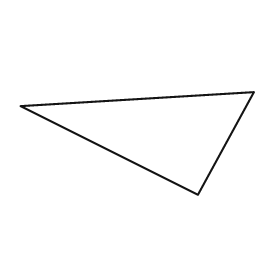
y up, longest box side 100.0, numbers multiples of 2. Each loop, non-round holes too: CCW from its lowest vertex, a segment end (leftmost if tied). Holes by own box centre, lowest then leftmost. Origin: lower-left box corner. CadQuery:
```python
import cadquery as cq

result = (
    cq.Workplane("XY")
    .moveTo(76.0, 0.0)
    .lineTo(100.0, 44.0)
    .lineTo(0.0, 38.0)
    .close()
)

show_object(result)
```